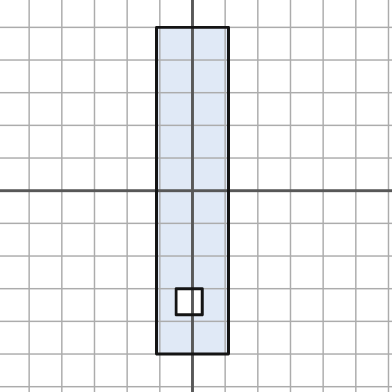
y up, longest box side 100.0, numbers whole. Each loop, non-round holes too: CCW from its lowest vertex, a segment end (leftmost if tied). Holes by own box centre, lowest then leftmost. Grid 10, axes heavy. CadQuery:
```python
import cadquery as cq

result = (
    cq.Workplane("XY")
    .moveTo(-11.0, -50.0)
    .lineTo(11.0, -50.0)
    .lineTo(11.0, 50.0)
    .lineTo(-11.0, 50.0)
    .close()
    .moveTo(-5.0, -38.0)
    .lineTo(3.0, -38.0)
    .lineTo(3.0, -30.0)
    .lineTo(-5.0, -30.0)
    .close()
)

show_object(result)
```